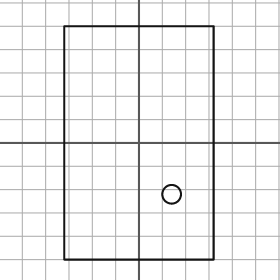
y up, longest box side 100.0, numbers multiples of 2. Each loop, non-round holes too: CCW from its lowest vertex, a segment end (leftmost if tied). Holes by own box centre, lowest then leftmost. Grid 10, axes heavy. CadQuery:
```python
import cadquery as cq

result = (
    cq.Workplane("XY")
    .moveTo(-32.0, -50.0)
    .lineTo(32.0, -50.0)
    .lineTo(32.0, 50.0)
    .lineTo(-32.0, 50.0)
    .close()
    .moveTo(14.0, -22.0)
    .circle(4.0)
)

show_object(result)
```